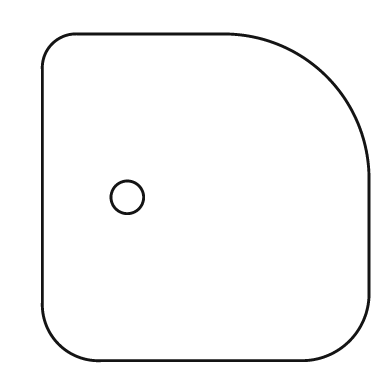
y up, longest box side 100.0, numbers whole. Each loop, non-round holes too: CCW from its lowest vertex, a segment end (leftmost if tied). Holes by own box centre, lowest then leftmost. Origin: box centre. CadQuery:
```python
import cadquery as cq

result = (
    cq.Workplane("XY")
    .moveTo(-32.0, -50.0)
    .lineTo(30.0, -50.0)
    .threePointArc((44.0, -44.0), (50.0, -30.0))
    .lineTo(50.0, 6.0)
    .threePointArc((37.0, 37.0), (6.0, 50.0))
    .lineTo(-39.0, 50.0)
    .threePointArc((-47.0, 47.0), (-50.0, 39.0))
    .lineTo(-50.0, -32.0)
    .threePointArc((-45.0, -45.0), (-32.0, -50.0))
    .close()
    .moveTo(-24.0, 0.0)
    .circle(5.0)
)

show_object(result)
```